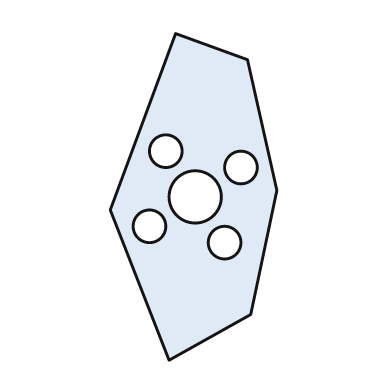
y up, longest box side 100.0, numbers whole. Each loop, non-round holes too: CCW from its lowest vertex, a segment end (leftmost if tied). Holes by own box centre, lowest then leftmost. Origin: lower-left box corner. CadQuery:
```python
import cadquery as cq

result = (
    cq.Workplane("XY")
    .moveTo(18.0, 0.0)
    .lineTo(43.0, 14.0)
    .lineTo(51.0, 52.0)
    .lineTo(42.0, 92.0)
    .lineTo(20.0, 100.0)
    .lineTo(0.0, 46.0)
    .close()
    .moveTo(35.0, 36.0)
    .circle(5.0)
    .moveTo(12.0, 41.0)
    .circle(5.0)
    .moveTo(26.0, 50.0)
    .circle(8.0)
    .moveTo(40.0, 59.0)
    .circle(5.0)
    .moveTo(17.0, 64.0)
    .circle(5.0)
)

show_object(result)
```